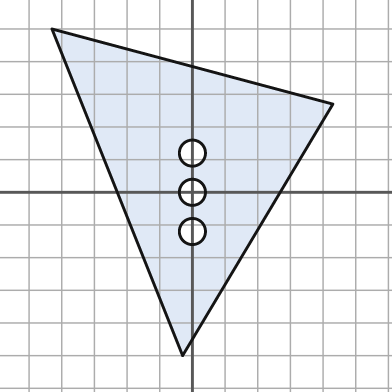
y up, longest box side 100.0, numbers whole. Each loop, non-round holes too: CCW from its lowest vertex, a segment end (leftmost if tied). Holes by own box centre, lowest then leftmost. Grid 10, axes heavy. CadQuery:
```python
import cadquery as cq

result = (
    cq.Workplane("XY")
    .moveTo(-3.0, -50.0)
    .lineTo(43.0, 27.0)
    .lineTo(-43.0, 50.0)
    .close()
    .moveTo(0.0, -12.0)
    .circle(4.0)
    .moveTo(0.0, 0.0)
    .circle(4.0)
    .moveTo(0.0, 12.0)
    .circle(4.0)
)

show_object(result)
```